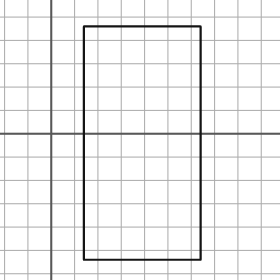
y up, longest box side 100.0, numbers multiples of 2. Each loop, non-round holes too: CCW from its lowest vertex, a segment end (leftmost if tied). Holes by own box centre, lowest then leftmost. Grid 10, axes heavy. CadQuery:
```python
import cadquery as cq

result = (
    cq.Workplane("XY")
    .moveTo(14.0, -54.0)
    .lineTo(64.0, -54.0)
    .lineTo(64.0, 46.0)
    .lineTo(14.0, 46.0)
    .close()
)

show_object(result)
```